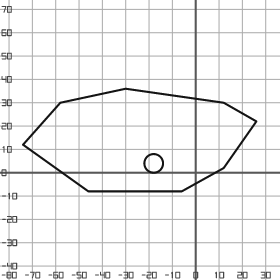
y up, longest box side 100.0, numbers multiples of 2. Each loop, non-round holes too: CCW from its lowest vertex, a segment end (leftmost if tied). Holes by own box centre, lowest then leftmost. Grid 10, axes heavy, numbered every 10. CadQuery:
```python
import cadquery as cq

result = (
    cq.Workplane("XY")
    .moveTo(-46.0, -8.0)
    .lineTo(-6.0, -8.0)
    .lineTo(12.0, 2.0)
    .lineTo(26.0, 22.0)
    .lineTo(12.0, 30.0)
    .lineTo(-30.0, 36.0)
    .lineTo(-58.0, 30.0)
    .lineTo(-74.0, 12.0)
    .close()
    .moveTo(-18.0, 4.0)
    .circle(4.0)
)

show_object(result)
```